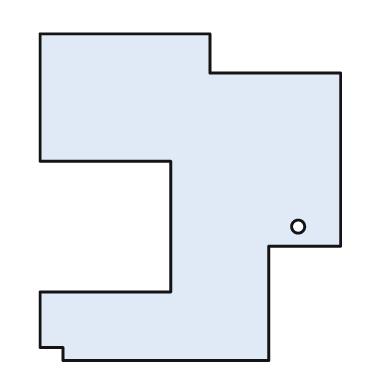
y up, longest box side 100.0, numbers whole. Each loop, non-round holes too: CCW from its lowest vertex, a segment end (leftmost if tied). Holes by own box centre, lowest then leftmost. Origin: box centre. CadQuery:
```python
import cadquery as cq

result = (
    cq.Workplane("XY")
    .moveTo(-39.0, -50.0)
    .lineTo(24.0, -50.0)
    .lineTo(24.0, -15.0)
    .lineTo(46.0, -15.0)
    .lineTo(46.0, 38.0)
    .lineTo(6.0, 38.0)
    .lineTo(6.0, 50.0)
    .lineTo(-46.0, 50.0)
    .lineTo(-46.0, 11.0)
    .lineTo(-6.0, 11.0)
    .lineTo(-6.0, -29.0)
    .lineTo(-46.0, -29.0)
    .lineTo(-46.0, -46.0)
    .lineTo(-39.0, -46.0)
    .close()
    .moveTo(33.0, -9.0)
    .circle(2.0)
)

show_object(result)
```